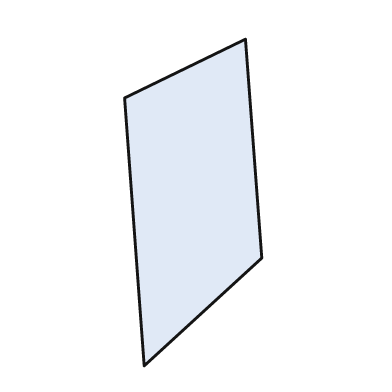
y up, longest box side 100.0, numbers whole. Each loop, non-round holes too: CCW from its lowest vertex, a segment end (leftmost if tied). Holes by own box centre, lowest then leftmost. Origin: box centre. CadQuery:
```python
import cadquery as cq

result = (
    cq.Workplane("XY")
    .moveTo(-15.0, -50.0)
    .lineTo(21.0, -17.0)
    .lineTo(16.0, 50.0)
    .lineTo(-21.0, 32.0)
    .close()
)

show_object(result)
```